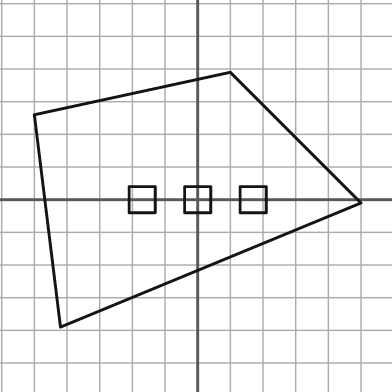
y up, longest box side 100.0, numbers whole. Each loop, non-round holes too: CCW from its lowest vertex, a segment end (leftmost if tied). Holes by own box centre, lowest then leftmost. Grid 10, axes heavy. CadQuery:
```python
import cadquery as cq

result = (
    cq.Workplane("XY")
    .moveTo(-42.0, -39.0)
    .lineTo(50.0, -1.0)
    .lineTo(10.0, 39.0)
    .lineTo(-50.0, 26.0)
    .close()
    .moveTo(-21.0, -4.0)
    .lineTo(-13.0, -4.0)
    .lineTo(-13.0, 4.0)
    .lineTo(-21.0, 4.0)
    .close()
    .moveTo(-4.0, -4.0)
    .lineTo(4.0, -4.0)
    .lineTo(4.0, 4.0)
    .lineTo(-4.0, 4.0)
    .close()
    .moveTo(13.0, -4.0)
    .lineTo(21.0, -4.0)
    .lineTo(21.0, 4.0)
    .lineTo(13.0, 4.0)
    .close()
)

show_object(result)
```